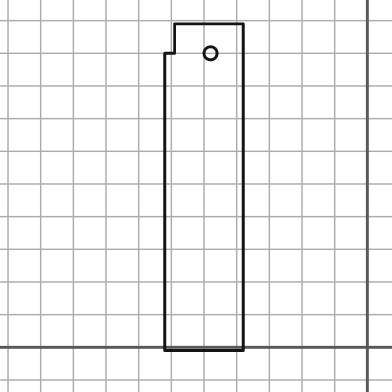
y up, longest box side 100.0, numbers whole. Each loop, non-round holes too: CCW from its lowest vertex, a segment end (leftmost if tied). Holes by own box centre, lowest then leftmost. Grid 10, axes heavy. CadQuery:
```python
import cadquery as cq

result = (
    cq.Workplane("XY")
    .moveTo(-62.0, -1.0)
    .lineTo(-38.0, -1.0)
    .lineTo(-38.0, 99.0)
    .lineTo(-59.0, 99.0)
    .lineTo(-59.0, 90.0)
    .lineTo(-62.0, 90.0)
    .close()
    .moveTo(-48.0, 90.0)
    .circle(2.0)
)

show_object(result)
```